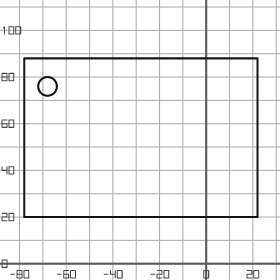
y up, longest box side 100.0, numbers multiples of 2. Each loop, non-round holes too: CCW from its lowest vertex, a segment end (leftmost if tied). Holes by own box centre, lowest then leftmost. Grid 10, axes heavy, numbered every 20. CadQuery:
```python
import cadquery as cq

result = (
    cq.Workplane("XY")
    .moveTo(-78.0, 20.0)
    .lineTo(22.0, 20.0)
    .lineTo(22.0, 88.0)
    .lineTo(-78.0, 88.0)
    .close()
    .moveTo(-68.0, 76.0)
    .circle(4.0)
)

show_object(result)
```